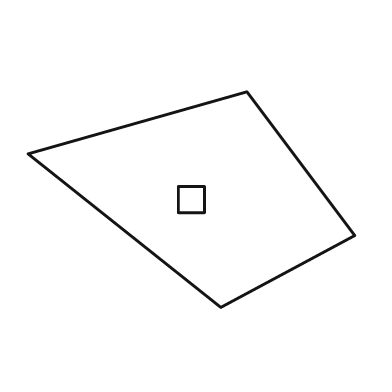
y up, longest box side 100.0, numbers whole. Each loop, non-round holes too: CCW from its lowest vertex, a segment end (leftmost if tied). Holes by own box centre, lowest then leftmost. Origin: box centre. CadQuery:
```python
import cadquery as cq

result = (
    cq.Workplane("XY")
    .moveTo(9.0, -33.0)
    .lineTo(50.0, -11.0)
    .lineTo(17.0, 33.0)
    .lineTo(-50.0, 14.0)
    .close()
    .moveTo(-4.0, -4.0)
    .lineTo(4.0, -4.0)
    .lineTo(4.0, 4.0)
    .lineTo(-4.0, 4.0)
    .close()
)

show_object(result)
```